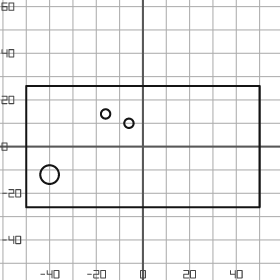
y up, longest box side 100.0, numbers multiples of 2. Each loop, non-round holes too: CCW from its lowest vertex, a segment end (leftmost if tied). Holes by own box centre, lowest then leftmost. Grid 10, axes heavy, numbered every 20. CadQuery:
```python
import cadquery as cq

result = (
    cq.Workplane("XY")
    .moveTo(-50.0, -26.0)
    .lineTo(50.0, -26.0)
    .lineTo(50.0, 26.0)
    .lineTo(-50.0, 26.0)
    .close()
    .moveTo(-40.0, -12.0)
    .circle(4.0)
    .moveTo(-6.0, 10.0)
    .circle(2.0)
    .moveTo(-16.0, 14.0)
    .circle(2.0)
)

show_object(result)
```